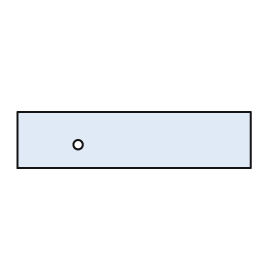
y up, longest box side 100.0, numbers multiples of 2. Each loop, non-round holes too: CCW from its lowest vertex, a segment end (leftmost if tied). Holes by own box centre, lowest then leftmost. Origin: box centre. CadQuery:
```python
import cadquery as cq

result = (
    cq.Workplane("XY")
    .moveTo(-50.0, -12.0)
    .lineTo(50.0, -12.0)
    .lineTo(50.0, 12.0)
    .lineTo(-50.0, 12.0)
    .close()
    .moveTo(-24.0, -2.0)
    .circle(2.0)
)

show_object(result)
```